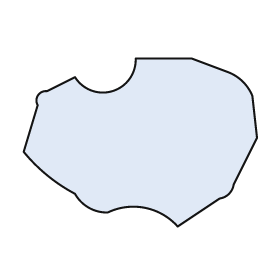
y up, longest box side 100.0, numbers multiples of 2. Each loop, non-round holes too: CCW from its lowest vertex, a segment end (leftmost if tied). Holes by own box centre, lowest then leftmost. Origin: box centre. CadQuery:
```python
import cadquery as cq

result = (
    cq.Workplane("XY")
    .moveTo(16.0, -36.0)
    .lineTo(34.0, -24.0)
    .threePointArc((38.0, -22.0), (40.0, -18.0))
    .lineTo(50.0, 2.0)
    .lineTo(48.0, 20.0)
    .threePointArc((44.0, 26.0), (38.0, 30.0))
    .lineTo(22.0, 36.0)
    .lineTo(-2.0, 36.0)
    .threePointArc((-12.0, 22.0), (-28.0, 28.0))
    .lineTo(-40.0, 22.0)
    .threePointArc((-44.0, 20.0), (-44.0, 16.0))
    .lineTo(-50.0, -4.0)
    .threePointArc((-40.0, -14.0), (-28.0, -22.0))
    .threePointArc((-22.0, -28.0), (-14.0, -30.0))
    .threePointArc((2.0, -28.0), (16.0, -36.0))
    .close()
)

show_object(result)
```